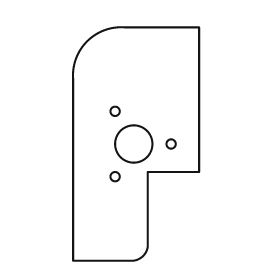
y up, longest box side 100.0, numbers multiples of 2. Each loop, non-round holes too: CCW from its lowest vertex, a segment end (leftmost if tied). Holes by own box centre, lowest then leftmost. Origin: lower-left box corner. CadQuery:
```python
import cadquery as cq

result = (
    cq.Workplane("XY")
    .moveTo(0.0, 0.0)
    .lineTo(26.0, 0.0)
    .threePointArc((30.0, 2.0), (32.0, 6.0))
    .lineTo(32.0, 38.0)
    .lineTo(54.0, 38.0)
    .lineTo(54.0, 100.0)
    .lineTo(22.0, 100.0)
    .threePointArc((6.0, 94.0), (0.0, 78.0))
    .close()
    .moveTo(18.0, 36.0)
    .circle(2.0)
    .moveTo(26.0, 50.0)
    .circle(8.0)
    .moveTo(42.0, 50.0)
    .circle(2.0)
    .moveTo(18.0, 64.0)
    .circle(2.0)
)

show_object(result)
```